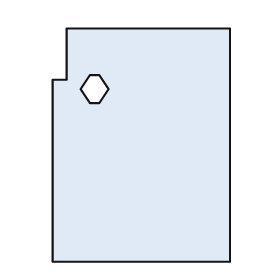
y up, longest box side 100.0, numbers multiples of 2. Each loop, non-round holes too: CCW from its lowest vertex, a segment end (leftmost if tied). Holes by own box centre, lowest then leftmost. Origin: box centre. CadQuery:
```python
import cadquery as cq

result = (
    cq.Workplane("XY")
    .moveTo(-38.0, -50.0)
    .lineTo(38.0, -50.0)
    .lineTo(38.0, 50.0)
    .lineTo(-32.0, 50.0)
    .lineTo(-32.0, 28.0)
    .lineTo(-38.0, 28.0)
    .close()
    .moveTo(-22.0, 18.0)
    .lineTo(-18.0, 18.0)
    .lineTo(-14.0, 24.0)
    .lineTo(-18.0, 30.0)
    .lineTo(-22.0, 30.0)
    .lineTo(-26.0, 24.0)
    .close()
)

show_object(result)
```